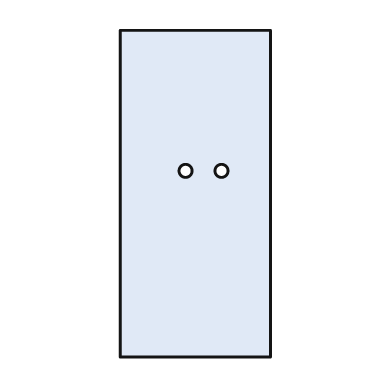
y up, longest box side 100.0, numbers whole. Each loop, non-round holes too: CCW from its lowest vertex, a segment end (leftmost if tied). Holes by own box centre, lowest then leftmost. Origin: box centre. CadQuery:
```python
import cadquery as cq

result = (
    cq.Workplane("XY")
    .moveTo(-23.0, -50.0)
    .lineTo(23.0, -50.0)
    .lineTo(23.0, 50.0)
    .lineTo(-23.0, 50.0)
    .close()
    .moveTo(-3.0, 7.0)
    .circle(2.0)
    .moveTo(8.0, 7.0)
    .circle(2.0)
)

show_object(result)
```